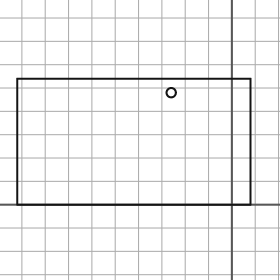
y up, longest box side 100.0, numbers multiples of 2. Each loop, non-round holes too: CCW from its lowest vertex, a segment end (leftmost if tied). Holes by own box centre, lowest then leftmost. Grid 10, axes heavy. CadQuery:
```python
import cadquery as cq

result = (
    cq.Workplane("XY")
    .moveTo(-92.0, 0.0)
    .lineTo(8.0, 0.0)
    .lineTo(8.0, 54.0)
    .lineTo(-92.0, 54.0)
    .close()
    .moveTo(-26.0, 48.0)
    .circle(2.0)
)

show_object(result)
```